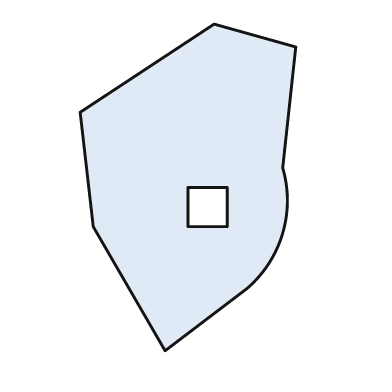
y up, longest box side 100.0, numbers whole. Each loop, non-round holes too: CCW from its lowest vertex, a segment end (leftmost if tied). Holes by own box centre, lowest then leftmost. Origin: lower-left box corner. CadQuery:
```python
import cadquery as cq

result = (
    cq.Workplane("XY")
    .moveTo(26.0, 0.0)
    .lineTo(51.0, 19.0)
    .threePointArc((62.0, 36.0), (62.0, 56.0))
    .lineTo(66.0, 93.0)
    .lineTo(41.0, 100.0)
    .lineTo(0.0, 73.0)
    .lineTo(4.0, 38.0)
    .close()
    .moveTo(33.0, 38.0)
    .lineTo(45.0, 38.0)
    .lineTo(45.0, 50.0)
    .lineTo(33.0, 50.0)
    .close()
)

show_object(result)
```